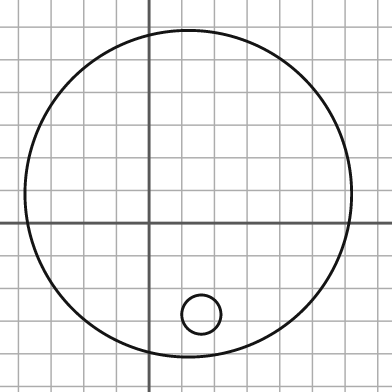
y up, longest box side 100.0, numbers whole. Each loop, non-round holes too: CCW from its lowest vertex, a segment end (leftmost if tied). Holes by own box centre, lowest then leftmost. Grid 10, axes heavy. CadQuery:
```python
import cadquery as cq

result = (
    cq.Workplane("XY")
    .moveTo(12.0, 9.0)
    .circle(50.0)
    .moveTo(16.0, -28.0)
    .circle(6.0)
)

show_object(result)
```